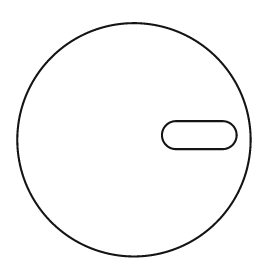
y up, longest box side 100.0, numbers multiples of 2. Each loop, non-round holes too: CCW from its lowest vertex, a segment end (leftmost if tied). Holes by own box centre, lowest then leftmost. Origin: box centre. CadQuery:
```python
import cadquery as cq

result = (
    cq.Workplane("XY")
    .moveTo(0.0, 0.0)
    .circle(50.0)
    .moveTo(18.0, -4.0)
    .lineTo(38.0, -4.0)
    .threePointArc((44.0, 2.0), (38.0, 8.0))
    .lineTo(18.0, 8.0)
    .threePointArc((12.0, 2.0), (18.0, -4.0))
    .close()
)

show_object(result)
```